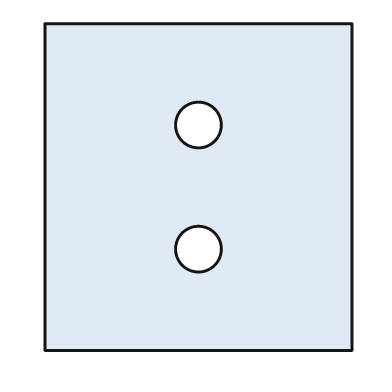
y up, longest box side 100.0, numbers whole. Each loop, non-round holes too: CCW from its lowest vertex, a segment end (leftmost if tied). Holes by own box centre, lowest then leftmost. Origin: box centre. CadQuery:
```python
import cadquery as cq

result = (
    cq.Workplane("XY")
    .moveTo(-47.0, -50.0)
    .lineTo(47.0, -50.0)
    .lineTo(47.0, 50.0)
    .lineTo(-47.0, 50.0)
    .close()
    .moveTo(0.0, -19.0)
    .circle(7.0)
    .moveTo(0.0, 19.0)
    .circle(7.0)
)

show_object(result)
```